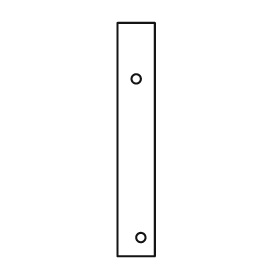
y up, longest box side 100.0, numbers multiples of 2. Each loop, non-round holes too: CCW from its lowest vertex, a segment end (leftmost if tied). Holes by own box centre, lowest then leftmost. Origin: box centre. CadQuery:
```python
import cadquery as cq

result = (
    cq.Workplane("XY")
    .moveTo(-8.0, -50.0)
    .lineTo(8.0, -50.0)
    .lineTo(8.0, 50.0)
    .lineTo(-8.0, 50.0)
    .close()
    .moveTo(2.0, -42.0)
    .circle(2.0)
    .moveTo(0.0, 26.0)
    .circle(2.0)
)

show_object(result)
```